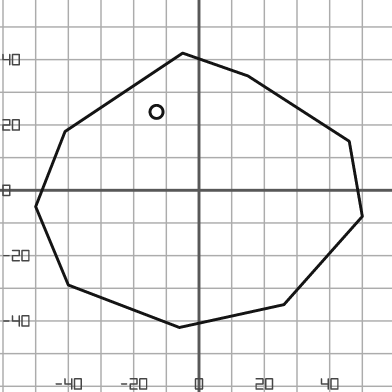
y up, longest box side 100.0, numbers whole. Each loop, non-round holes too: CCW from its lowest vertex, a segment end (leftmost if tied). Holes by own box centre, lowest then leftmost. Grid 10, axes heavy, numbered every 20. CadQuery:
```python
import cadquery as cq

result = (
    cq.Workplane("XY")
    .moveTo(-6.0, -42.0)
    .lineTo(26.0, -35.0)
    .lineTo(50.0, -8.0)
    .lineTo(46.0, 15.0)
    .lineTo(15.0, 35.0)
    .lineTo(-5.0, 42.0)
    .lineTo(-41.0, 18.0)
    .lineTo(-50.0, -5.0)
    .lineTo(-40.0, -29.0)
    .close()
    .moveTo(-13.0, 24.0)
    .circle(2.0)
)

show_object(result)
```